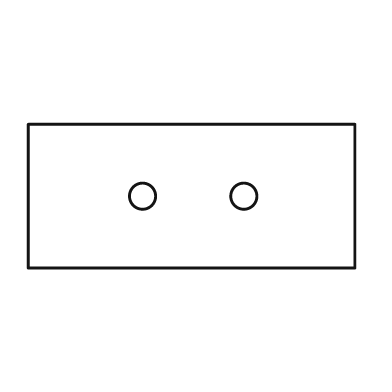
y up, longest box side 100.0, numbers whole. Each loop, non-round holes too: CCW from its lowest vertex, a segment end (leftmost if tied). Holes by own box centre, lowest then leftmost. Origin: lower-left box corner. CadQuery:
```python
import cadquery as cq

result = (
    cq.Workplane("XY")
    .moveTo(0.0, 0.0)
    .lineTo(100.0, 0.0)
    .lineTo(100.0, 44.0)
    .lineTo(0.0, 44.0)
    .close()
    .moveTo(35.0, 22.0)
    .circle(4.0)
    .moveTo(66.0, 22.0)
    .circle(4.0)
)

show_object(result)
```